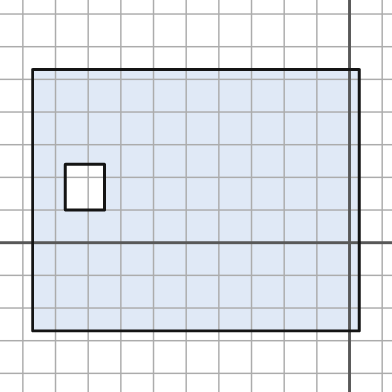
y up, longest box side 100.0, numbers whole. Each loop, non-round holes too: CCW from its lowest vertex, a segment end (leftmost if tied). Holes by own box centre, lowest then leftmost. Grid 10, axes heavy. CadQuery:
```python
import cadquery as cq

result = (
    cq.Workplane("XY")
    .moveTo(-97.0, -27.0)
    .lineTo(3.0, -27.0)
    .lineTo(3.0, 53.0)
    .lineTo(-97.0, 53.0)
    .close()
    .moveTo(-87.0, 10.0)
    .lineTo(-75.0, 10.0)
    .lineTo(-75.0, 24.0)
    .lineTo(-87.0, 24.0)
    .close()
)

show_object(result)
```